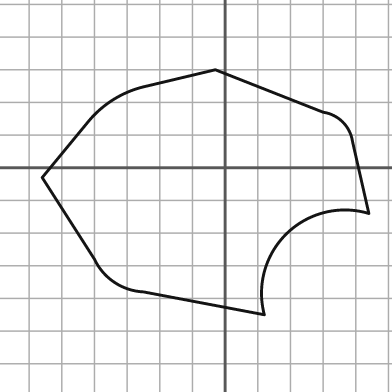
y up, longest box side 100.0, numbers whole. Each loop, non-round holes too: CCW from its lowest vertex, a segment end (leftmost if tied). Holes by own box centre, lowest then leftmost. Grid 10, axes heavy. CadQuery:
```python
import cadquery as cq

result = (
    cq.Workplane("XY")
    .moveTo(12.0, -45.0)
    .threePointArc((19.0, -20.0), (44.0, -14.0))
    .lineTo(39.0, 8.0)
    .threePointArc((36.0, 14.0), (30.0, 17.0))
    .lineTo(-3.0, 30.0)
    .lineTo(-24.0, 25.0)
    .threePointArc((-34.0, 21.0), (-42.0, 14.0))
    .lineTo(-56.0, -3.0)
    .lineTo(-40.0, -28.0)
    .threePointArc((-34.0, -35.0), (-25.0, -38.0))
    .close()
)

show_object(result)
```